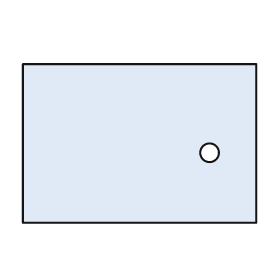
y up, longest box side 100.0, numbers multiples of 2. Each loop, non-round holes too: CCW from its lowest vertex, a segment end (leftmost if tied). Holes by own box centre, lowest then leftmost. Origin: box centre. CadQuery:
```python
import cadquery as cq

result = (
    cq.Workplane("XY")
    .moveTo(-50.0, -34.0)
    .lineTo(50.0, -34.0)
    .lineTo(50.0, 34.0)
    .lineTo(-50.0, 34.0)
    .close()
    .moveTo(30.0, -4.0)
    .circle(4.0)
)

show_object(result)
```